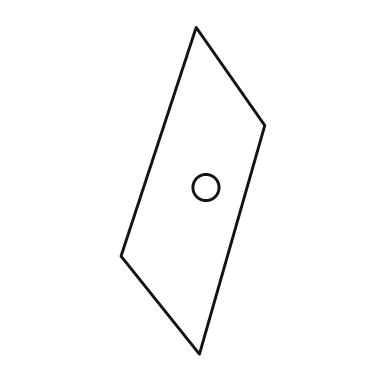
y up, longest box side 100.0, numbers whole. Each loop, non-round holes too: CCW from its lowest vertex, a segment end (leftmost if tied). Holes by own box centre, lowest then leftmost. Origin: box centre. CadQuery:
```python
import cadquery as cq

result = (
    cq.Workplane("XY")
    .moveTo(2.0, -50.0)
    .lineTo(22.0, 20.0)
    .lineTo(1.0, 50.0)
    .lineTo(-22.0, -20.0)
    .close()
    .moveTo(4.0, 1.0)
    .circle(4.0)
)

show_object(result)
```